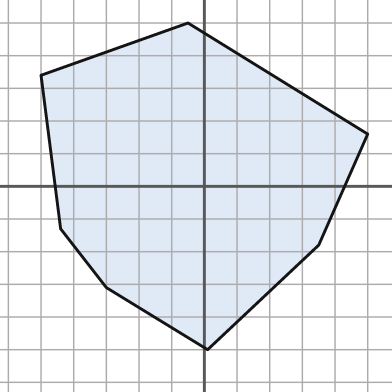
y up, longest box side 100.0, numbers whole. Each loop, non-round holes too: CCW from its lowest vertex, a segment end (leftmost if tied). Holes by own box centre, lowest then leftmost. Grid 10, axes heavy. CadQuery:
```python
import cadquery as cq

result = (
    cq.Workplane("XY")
    .moveTo(1.0, -50.0)
    .lineTo(35.0, -18.0)
    .lineTo(50.0, 16.0)
    .lineTo(-5.0, 50.0)
    .lineTo(-50.0, 34.0)
    .lineTo(-44.0, -13.0)
    .lineTo(-30.0, -31.0)
    .close()
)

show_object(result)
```